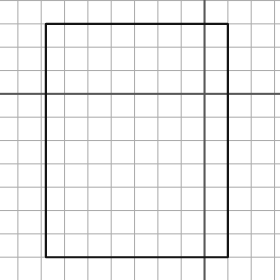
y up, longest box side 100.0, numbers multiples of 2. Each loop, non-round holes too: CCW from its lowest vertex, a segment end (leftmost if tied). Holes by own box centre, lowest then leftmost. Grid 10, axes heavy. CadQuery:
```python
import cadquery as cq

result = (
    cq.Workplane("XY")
    .moveTo(-68.0, -70.0)
    .lineTo(10.0, -70.0)
    .lineTo(10.0, 30.0)
    .lineTo(-68.0, 30.0)
    .close()
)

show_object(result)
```